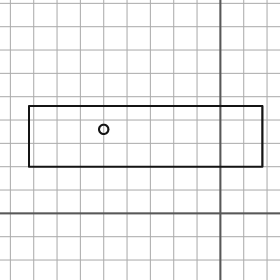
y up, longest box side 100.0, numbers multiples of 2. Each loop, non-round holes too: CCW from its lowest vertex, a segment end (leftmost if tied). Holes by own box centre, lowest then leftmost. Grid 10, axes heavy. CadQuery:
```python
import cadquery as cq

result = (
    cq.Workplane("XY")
    .moveTo(-82.0, 20.0)
    .lineTo(18.0, 20.0)
    .lineTo(18.0, 46.0)
    .lineTo(-82.0, 46.0)
    .close()
    .moveTo(-50.0, 36.0)
    .circle(2.0)
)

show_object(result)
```